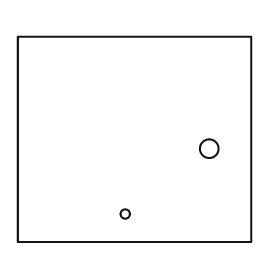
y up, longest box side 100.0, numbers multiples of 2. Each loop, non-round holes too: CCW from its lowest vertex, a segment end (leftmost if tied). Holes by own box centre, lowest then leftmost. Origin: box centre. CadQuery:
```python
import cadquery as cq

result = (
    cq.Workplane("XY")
    .moveTo(-50.0, -44.0)
    .lineTo(50.0, -44.0)
    .lineTo(50.0, 44.0)
    .lineTo(-50.0, 44.0)
    .close()
    .moveTo(-4.0, -32.0)
    .circle(2.0)
    .moveTo(32.0, -4.0)
    .circle(4.0)
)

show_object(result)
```